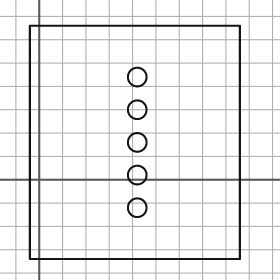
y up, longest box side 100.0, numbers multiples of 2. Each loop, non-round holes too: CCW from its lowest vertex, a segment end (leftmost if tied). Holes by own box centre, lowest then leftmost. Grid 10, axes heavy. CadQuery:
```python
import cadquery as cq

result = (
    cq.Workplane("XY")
    .moveTo(-4.0, -34.0)
    .lineTo(86.0, -34.0)
    .lineTo(86.0, 66.0)
    .lineTo(-4.0, 66.0)
    .close()
    .moveTo(42.0, -12.0)
    .circle(4.0)
    .moveTo(42.0, 2.0)
    .circle(4.0)
    .moveTo(42.0, 16.0)
    .circle(4.0)
    .moveTo(42.0, 30.0)
    .circle(4.0)
    .moveTo(42.0, 44.0)
    .circle(4.0)
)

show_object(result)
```